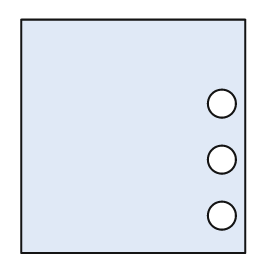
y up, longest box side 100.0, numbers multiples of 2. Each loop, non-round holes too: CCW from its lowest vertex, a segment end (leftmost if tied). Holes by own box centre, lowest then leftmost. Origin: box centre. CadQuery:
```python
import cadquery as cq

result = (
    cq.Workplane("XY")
    .moveTo(-48.0, -50.0)
    .lineTo(48.0, -50.0)
    .lineTo(48.0, 50.0)
    .lineTo(-48.0, 50.0)
    .close()
    .moveTo(38.0, -34.0)
    .circle(6.0)
    .moveTo(38.0, -10.0)
    .circle(6.0)
    .moveTo(38.0, 14.0)
    .circle(6.0)
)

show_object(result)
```